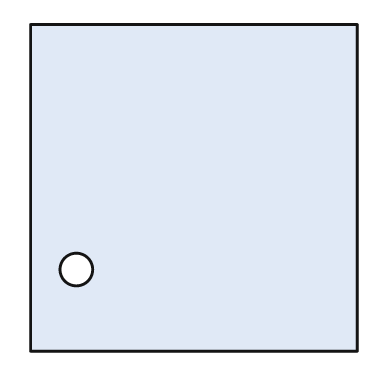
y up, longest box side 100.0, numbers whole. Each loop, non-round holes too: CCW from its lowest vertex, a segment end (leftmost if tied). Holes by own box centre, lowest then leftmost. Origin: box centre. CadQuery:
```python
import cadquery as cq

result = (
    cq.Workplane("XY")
    .moveTo(-50.0, -50.0)
    .lineTo(50.0, -50.0)
    .lineTo(50.0, 50.0)
    .lineTo(-50.0, 50.0)
    .close()
    .moveTo(-36.0, -25.0)
    .circle(5.0)
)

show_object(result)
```